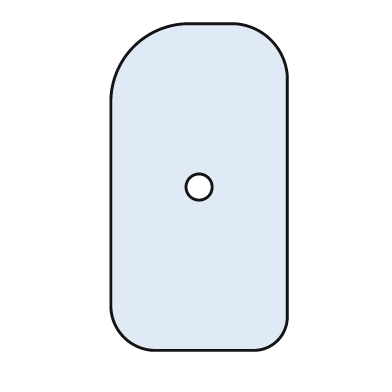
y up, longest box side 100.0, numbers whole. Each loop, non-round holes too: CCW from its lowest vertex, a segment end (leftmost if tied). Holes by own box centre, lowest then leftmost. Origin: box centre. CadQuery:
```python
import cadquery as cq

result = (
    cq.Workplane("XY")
    .moveTo(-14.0, -50.0)
    .lineTo(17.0, -50.0)
    .threePointArc((24.0, -47.0), (27.0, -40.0))
    .lineTo(27.0, 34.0)
    .threePointArc((22.0, 45.0), (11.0, 50.0))
    .lineTo(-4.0, 50.0)
    .threePointArc((-20.0, 43.0), (-27.0, 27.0))
    .lineTo(-27.0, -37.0)
    .threePointArc((-23.0, -46.0), (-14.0, -50.0))
    .close()
    .moveTo(0.0, 0.0)
    .circle(4.0)
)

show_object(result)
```